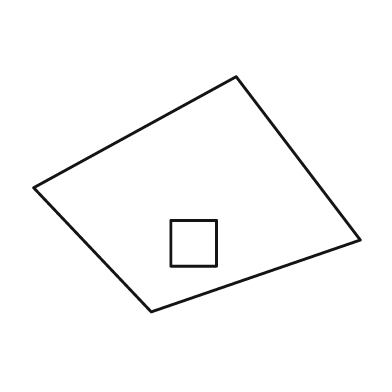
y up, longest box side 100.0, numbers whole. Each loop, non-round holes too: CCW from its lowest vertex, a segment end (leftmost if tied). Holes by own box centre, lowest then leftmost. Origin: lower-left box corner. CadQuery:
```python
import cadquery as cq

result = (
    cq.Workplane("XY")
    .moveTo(36.0, 0.0)
    .lineTo(100.0, 22.0)
    .lineTo(62.0, 72.0)
    .lineTo(0.0, 38.0)
    .close()
    .moveTo(42.0, 14.0)
    .lineTo(56.0, 14.0)
    .lineTo(56.0, 28.0)
    .lineTo(42.0, 28.0)
    .close()
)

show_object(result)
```